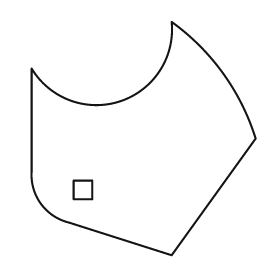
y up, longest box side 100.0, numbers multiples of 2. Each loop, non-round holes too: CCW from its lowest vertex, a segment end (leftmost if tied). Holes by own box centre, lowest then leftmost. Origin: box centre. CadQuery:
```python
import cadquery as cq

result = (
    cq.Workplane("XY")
    .moveTo(12.0, -50.0)
    .lineTo(48.0, 0.0)
    .threePointArc((34.0, 28.0), (12.0, 50.0))
    .threePointArc((-10.0, 16.0), (-48.0, 30.0))
    .lineTo(-48.0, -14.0)
    .threePointArc((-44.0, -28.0), (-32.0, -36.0))
    .close()
    .moveTo(-30.0, -26.0)
    .lineTo(-22.0, -26.0)
    .lineTo(-22.0, -18.0)
    .lineTo(-30.0, -18.0)
    .close()
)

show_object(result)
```